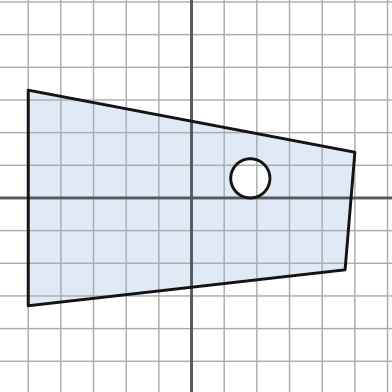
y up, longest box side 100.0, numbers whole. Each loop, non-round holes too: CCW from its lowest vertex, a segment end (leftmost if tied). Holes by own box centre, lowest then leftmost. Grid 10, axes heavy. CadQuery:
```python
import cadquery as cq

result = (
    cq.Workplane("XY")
    .moveTo(-50.0, -33.0)
    .lineTo(47.0, -22.0)
    .lineTo(50.0, 14.0)
    .lineTo(-50.0, 33.0)
    .close()
    .moveTo(18.0, 6.0)
    .circle(6.0)
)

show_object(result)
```